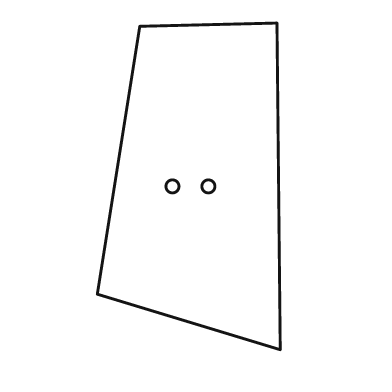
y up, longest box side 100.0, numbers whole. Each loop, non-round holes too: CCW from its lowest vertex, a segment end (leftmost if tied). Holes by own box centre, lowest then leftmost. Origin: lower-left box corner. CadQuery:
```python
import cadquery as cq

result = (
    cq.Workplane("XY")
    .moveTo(56.0, 0.0)
    .lineTo(55.0, 100.0)
    .lineTo(13.0, 99.0)
    .lineTo(0.0, 17.0)
    .close()
    .moveTo(23.0, 50.0)
    .circle(2.0)
    .moveTo(34.0, 50.0)
    .circle(2.0)
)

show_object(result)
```